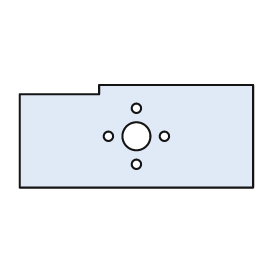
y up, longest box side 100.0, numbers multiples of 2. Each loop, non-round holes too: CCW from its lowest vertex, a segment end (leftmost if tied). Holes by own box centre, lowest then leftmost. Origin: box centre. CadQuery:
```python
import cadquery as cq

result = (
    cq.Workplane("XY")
    .moveTo(-50.0, -22.0)
    .lineTo(50.0, -22.0)
    .lineTo(50.0, 22.0)
    .lineTo(-16.0, 22.0)
    .lineTo(-16.0, 18.0)
    .lineTo(-50.0, 18.0)
    .close()
    .moveTo(0.0, -12.0)
    .circle(2.0)
    .moveTo(-12.0, 0.0)
    .circle(2.0)
    .moveTo(0.0, 0.0)
    .circle(6.0)
    .moveTo(12.0, 0.0)
    .circle(2.0)
    .moveTo(0.0, 12.0)
    .circle(2.0)
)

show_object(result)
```